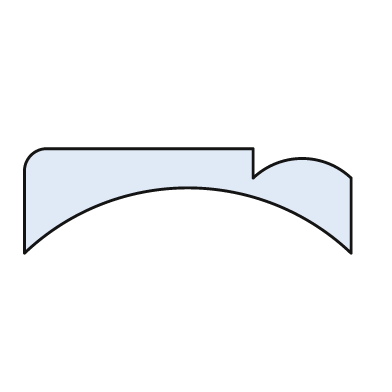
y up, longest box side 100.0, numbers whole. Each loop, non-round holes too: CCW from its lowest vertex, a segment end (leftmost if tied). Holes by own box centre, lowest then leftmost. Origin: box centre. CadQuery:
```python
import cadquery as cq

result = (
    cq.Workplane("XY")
    .moveTo(-50.0, -16.0)
    .threePointArc((0.0, 4.0), (50.0, -16.0))
    .lineTo(50.0, 7.0)
    .threePointArc((35.0, 13.0), (20.0, 7.0))
    .lineTo(20.0, 16.0)
    .lineTo(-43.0, 16.0)
    .threePointArc((-48.0, 14.0), (-50.0, 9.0))
    .close()
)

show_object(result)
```